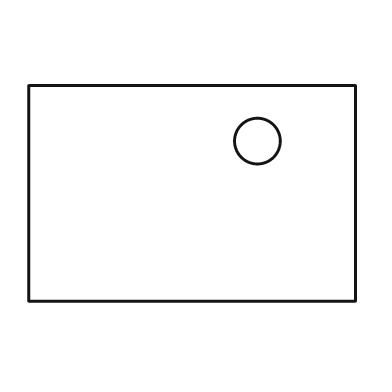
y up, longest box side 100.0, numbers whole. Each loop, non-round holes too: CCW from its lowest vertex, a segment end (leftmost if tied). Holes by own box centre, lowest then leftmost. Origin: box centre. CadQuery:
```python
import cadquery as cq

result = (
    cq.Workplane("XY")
    .moveTo(-50.0, -33.0)
    .lineTo(50.0, -33.0)
    .lineTo(50.0, 33.0)
    .lineTo(-50.0, 33.0)
    .close()
    .moveTo(20.0, 16.0)
    .circle(7.0)
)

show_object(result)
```